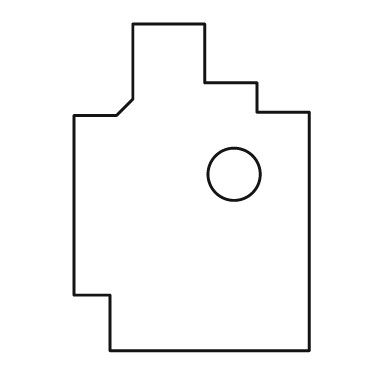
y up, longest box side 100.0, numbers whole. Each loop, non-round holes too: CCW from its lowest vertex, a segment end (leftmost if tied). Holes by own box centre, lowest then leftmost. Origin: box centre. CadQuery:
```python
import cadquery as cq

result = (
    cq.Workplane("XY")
    .moveTo(-25.0, -50.0)
    .lineTo(36.0, -50.0)
    .lineTo(36.0, 23.0)
    .lineTo(20.0, 23.0)
    .lineTo(20.0, 32.0)
    .lineTo(4.0, 32.0)
    .lineTo(4.0, 50.0)
    .lineTo(-18.0, 50.0)
    .lineTo(-18.0, 27.0)
    .lineTo(-23.0, 22.0)
    .lineTo(-36.0, 22.0)
    .lineTo(-36.0, -33.0)
    .lineTo(-25.0, -33.0)
    .close()
    .moveTo(13.0, 4.0)
    .circle(8.0)
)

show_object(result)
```